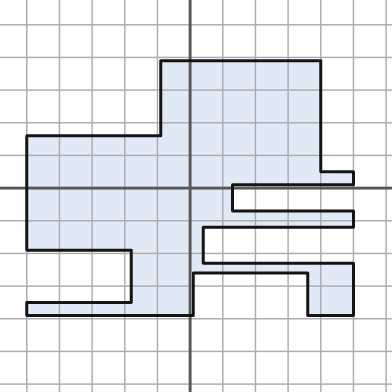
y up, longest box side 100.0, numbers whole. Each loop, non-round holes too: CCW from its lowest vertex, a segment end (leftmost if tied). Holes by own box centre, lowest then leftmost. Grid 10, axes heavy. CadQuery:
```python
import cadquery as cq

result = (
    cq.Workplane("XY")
    .moveTo(-50.0, -39.0)
    .lineTo(1.0, -39.0)
    .lineTo(1.0, -26.0)
    .lineTo(36.0, -26.0)
    .lineTo(36.0, -39.0)
    .lineTo(50.0, -39.0)
    .lineTo(50.0, -23.0)
    .lineTo(4.0, -23.0)
    .lineTo(4.0, -12.0)
    .lineTo(50.0, -12.0)
    .lineTo(50.0, -7.0)
    .lineTo(13.0, -7.0)
    .lineTo(13.0, 1.0)
    .lineTo(50.0, 1.0)
    .lineTo(50.0, 5.0)
    .lineTo(40.0, 5.0)
    .lineTo(40.0, 39.0)
    .lineTo(-9.0, 39.0)
    .lineTo(-9.0, 16.0)
    .lineTo(-50.0, 16.0)
    .lineTo(-50.0, -19.0)
    .lineTo(-18.0, -19.0)
    .lineTo(-18.0, -35.0)
    .lineTo(-50.0, -35.0)
    .close()
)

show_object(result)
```